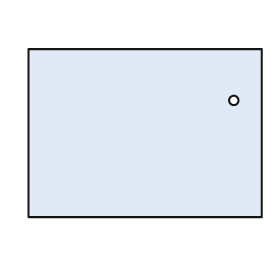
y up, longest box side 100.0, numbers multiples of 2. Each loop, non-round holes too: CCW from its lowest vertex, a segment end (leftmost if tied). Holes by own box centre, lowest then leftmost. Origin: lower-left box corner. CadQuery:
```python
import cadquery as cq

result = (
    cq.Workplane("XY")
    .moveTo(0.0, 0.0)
    .lineTo(100.0, 0.0)
    .lineTo(100.0, 72.0)
    .lineTo(0.0, 72.0)
    .close()
    .moveTo(88.0, 50.0)
    .circle(2.0)
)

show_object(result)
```